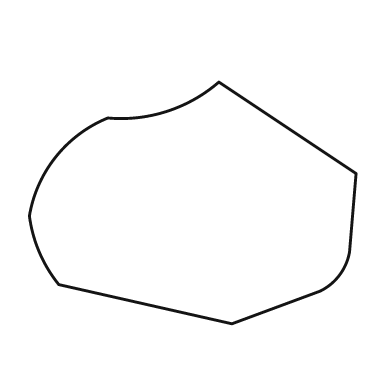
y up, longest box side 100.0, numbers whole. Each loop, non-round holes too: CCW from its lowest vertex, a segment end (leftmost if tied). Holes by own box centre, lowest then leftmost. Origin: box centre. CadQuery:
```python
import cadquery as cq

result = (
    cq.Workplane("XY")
    .moveTo(12.0, -37.0)
    .lineTo(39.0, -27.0)
    .threePointArc((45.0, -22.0), (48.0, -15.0))
    .lineTo(50.0, 9.0)
    .lineTo(8.0, 37.0)
    .threePointArc((-8.0, 28.0), (-26.0, 26.0))
    .threePointArc((-42.0, 14.0), (-50.0, -4.0))
    .threePointArc((-47.0, -15.0), (-41.0, -25.0))
    .close()
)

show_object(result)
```